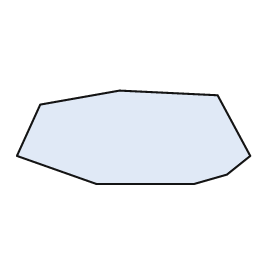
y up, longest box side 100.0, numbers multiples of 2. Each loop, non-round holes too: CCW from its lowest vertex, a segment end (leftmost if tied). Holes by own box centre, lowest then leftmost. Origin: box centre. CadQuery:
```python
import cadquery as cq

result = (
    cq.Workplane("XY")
    .moveTo(-16.0, -20.0)
    .lineTo(26.0, -20.0)
    .lineTo(40.0, -16.0)
    .lineTo(50.0, -8.0)
    .lineTo(36.0, 18.0)
    .lineTo(-6.0, 20.0)
    .lineTo(-40.0, 14.0)
    .lineTo(-50.0, -8.0)
    .close()
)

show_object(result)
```